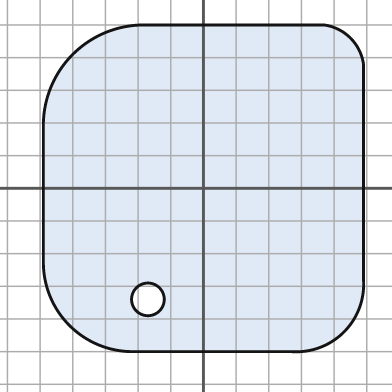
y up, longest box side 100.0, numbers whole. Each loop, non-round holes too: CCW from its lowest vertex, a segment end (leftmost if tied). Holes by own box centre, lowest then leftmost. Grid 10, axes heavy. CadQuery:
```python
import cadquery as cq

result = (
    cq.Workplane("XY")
    .moveTo(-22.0, -50.0)
    .lineTo(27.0, -50.0)
    .threePointArc((43.0, -44.0), (49.0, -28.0))
    .lineTo(49.0, 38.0)
    .threePointArc((45.0, 46.0), (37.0, 50.0))
    .lineTo(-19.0, 50.0)
    .threePointArc((-40.0, 41.0), (-49.0, 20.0))
    .lineTo(-49.0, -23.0)
    .threePointArc((-41.0, -42.0), (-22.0, -50.0))
    .close()
    .moveTo(-17.0, -34.0)
    .circle(5.0)
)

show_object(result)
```